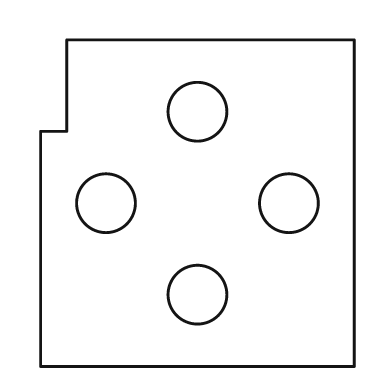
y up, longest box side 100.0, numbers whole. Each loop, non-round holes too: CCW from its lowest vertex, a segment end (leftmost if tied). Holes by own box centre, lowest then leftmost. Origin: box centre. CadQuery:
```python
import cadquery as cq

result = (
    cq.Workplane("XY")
    .moveTo(-48.0, -50.0)
    .lineTo(48.0, -50.0)
    .lineTo(48.0, 50.0)
    .lineTo(-40.0, 50.0)
    .lineTo(-40.0, 22.0)
    .lineTo(-48.0, 22.0)
    .close()
    .moveTo(0.0, -28.0)
    .circle(9.0)
    .moveTo(-28.0, 0.0)
    .circle(9.0)
    .moveTo(28.0, 0.0)
    .circle(9.0)
    .moveTo(0.0, 28.0)
    .circle(9.0)
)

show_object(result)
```